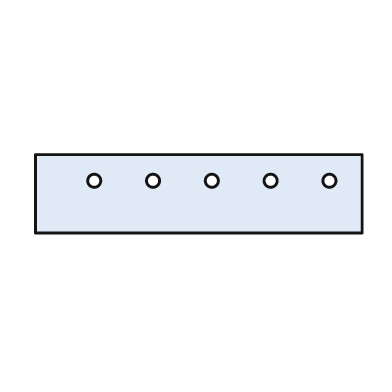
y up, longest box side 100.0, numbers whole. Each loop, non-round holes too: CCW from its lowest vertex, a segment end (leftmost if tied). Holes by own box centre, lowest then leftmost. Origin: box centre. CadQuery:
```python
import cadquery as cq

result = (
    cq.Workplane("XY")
    .moveTo(-50.0, -12.0)
    .lineTo(50.0, -12.0)
    .lineTo(50.0, 12.0)
    .lineTo(-50.0, 12.0)
    .close()
    .moveTo(-32.0, 4.0)
    .circle(2.0)
    .moveTo(-14.0, 4.0)
    .circle(2.0)
    .moveTo(4.0, 4.0)
    .circle(2.0)
    .moveTo(22.0, 4.0)
    .circle(2.0)
    .moveTo(40.0, 4.0)
    .circle(2.0)
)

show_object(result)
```